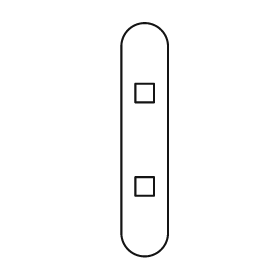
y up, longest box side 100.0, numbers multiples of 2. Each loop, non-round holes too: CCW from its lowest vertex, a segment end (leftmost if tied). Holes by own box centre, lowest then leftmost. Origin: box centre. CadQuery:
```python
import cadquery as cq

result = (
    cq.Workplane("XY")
    .moveTo(-10.0, -40.0)
    .threePointArc((0.0, -50.0), (10.0, -40.0))
    .lineTo(10.0, 40.0)
    .threePointArc((0.0, 50.0), (-10.0, 40.0))
    .close()
    .moveTo(-4.0, -24.0)
    .lineTo(4.0, -24.0)
    .lineTo(4.0, -16.0)
    .lineTo(-4.0, -16.0)
    .close()
    .moveTo(-4.0, 16.0)
    .lineTo(4.0, 16.0)
    .lineTo(4.0, 24.0)
    .lineTo(-4.0, 24.0)
    .close()
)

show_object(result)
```